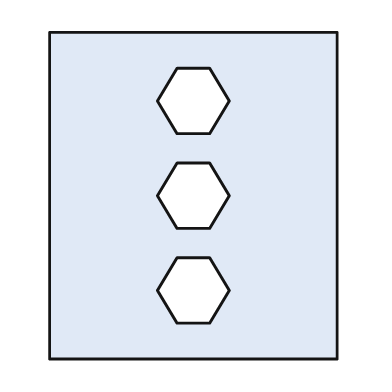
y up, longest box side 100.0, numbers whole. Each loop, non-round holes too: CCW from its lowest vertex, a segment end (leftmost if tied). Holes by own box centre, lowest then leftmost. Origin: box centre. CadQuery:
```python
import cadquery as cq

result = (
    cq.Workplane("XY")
    .moveTo(-44.0, -50.0)
    .lineTo(44.0, -50.0)
    .lineTo(44.0, 50.0)
    .lineTo(-44.0, 50.0)
    .close()
    .moveTo(-5.0, -39.0)
    .lineTo(5.0, -39.0)
    .lineTo(11.0, -29.0)
    .lineTo(5.0, -19.0)
    .lineTo(-5.0, -19.0)
    .lineTo(-11.0, -29.0)
    .close()
    .moveTo(-5.0, -10.0)
    .lineTo(5.0, -10.0)
    .lineTo(11.0, 0.0)
    .lineTo(5.0, 10.0)
    .lineTo(-5.0, 10.0)
    .lineTo(-11.0, 0.0)
    .close()
    .moveTo(-5.0, 19.0)
    .lineTo(5.0, 19.0)
    .lineTo(11.0, 29.0)
    .lineTo(5.0, 39.0)
    .lineTo(-5.0, 39.0)
    .lineTo(-11.0, 29.0)
    .close()
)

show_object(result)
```